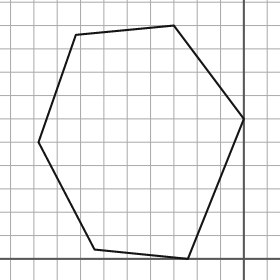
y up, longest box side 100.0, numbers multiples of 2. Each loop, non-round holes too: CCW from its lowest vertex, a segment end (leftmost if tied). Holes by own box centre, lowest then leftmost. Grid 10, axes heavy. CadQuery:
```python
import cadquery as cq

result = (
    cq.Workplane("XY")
    .moveTo(-24.0, 0.0)
    .lineTo(0.0, 60.0)
    .lineTo(-30.0, 100.0)
    .lineTo(-72.0, 96.0)
    .lineTo(-88.0, 50.0)
    .lineTo(-64.0, 4.0)
    .close()
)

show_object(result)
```